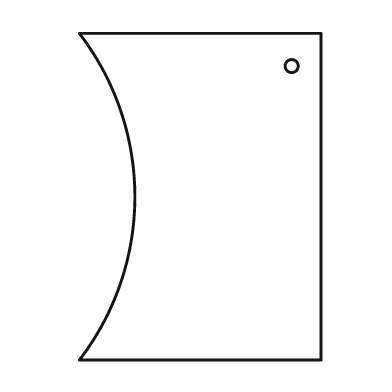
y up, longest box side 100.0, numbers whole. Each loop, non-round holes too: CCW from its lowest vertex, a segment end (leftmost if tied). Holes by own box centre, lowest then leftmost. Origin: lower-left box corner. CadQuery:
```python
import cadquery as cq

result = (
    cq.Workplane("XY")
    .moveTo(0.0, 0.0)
    .lineTo(74.0, 0.0)
    .lineTo(74.0, 100.0)
    .lineTo(0.0, 100.0)
    .threePointArc((17.0, 50.0), (0.0, 0.0))
    .close()
    .moveTo(65.0, 90.0)
    .circle(2.0)
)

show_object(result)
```